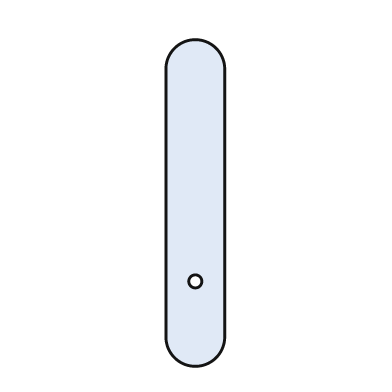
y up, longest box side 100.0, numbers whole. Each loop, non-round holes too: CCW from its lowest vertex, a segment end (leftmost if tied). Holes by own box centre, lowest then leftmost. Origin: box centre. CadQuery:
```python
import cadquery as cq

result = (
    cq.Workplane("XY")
    .moveTo(-9.0, -41.0)
    .threePointArc((0.0, -50.0), (9.0, -41.0))
    .lineTo(9.0, 41.0)
    .threePointArc((0.0, 50.0), (-9.0, 41.0))
    .close()
    .moveTo(0.0, -24.0)
    .circle(2.0)
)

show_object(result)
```